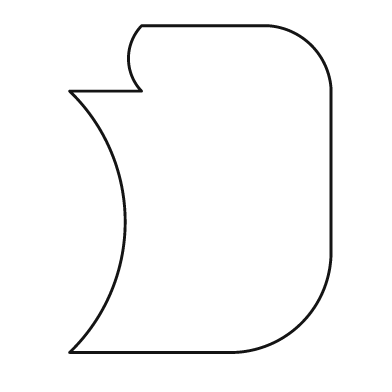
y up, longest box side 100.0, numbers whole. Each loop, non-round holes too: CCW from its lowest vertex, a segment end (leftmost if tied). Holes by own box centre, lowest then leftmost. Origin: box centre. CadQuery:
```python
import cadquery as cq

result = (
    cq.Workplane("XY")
    .moveTo(-40.0, -50.0)
    .lineTo(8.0, -50.0)
    .threePointArc((31.0, -41.0), (40.0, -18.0))
    .lineTo(40.0, 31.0)
    .threePointArc((34.0, 44.0), (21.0, 50.0))
    .lineTo(-18.0, 50.0)
    .threePointArc((-22.0, 40.0), (-18.0, 30.0))
    .lineTo(-40.0, 30.0)
    .threePointArc((-23.0, -10.0), (-40.0, -50.0))
    .close()
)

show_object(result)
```